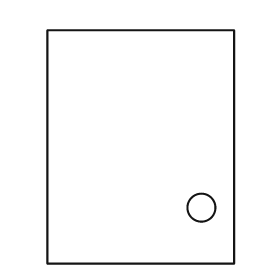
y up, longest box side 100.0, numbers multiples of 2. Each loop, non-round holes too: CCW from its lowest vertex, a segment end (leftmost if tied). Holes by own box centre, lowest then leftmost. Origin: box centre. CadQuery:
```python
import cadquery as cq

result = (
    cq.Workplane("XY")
    .moveTo(-40.0, -50.0)
    .lineTo(40.0, -50.0)
    .lineTo(40.0, 50.0)
    .lineTo(-40.0, 50.0)
    .close()
    .moveTo(26.0, -26.0)
    .circle(6.0)
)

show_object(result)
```